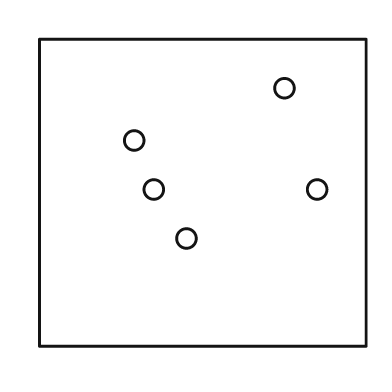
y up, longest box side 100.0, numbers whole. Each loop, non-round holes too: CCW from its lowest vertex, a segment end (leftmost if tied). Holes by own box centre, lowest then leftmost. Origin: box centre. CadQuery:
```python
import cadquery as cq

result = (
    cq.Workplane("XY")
    .moveTo(-50.0, -47.0)
    .lineTo(50.0, -47.0)
    .lineTo(50.0, 47.0)
    .lineTo(-50.0, 47.0)
    .close()
    .moveTo(-5.0, -14.0)
    .circle(3.0)
    .moveTo(-15.0, 1.0)
    .circle(3.0)
    .moveTo(35.0, 1.0)
    .circle(3.0)
    .moveTo(-21.0, 16.0)
    .circle(3.0)
    .moveTo(25.0, 32.0)
    .circle(3.0)
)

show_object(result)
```